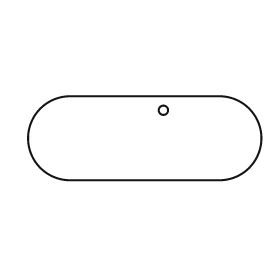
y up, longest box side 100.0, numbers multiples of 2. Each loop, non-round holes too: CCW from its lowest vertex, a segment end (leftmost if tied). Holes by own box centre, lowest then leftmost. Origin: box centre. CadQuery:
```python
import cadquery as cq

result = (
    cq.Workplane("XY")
    .moveTo(-32.0, -18.0)
    .lineTo(32.0, -18.0)
    .threePointArc((50.0, 0.0), (32.0, 18.0))
    .lineTo(-32.0, 18.0)
    .threePointArc((-50.0, 0.0), (-32.0, -18.0))
    .close()
    .moveTo(8.0, 12.0)
    .circle(2.0)
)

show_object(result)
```